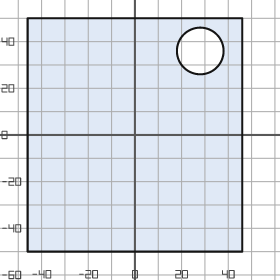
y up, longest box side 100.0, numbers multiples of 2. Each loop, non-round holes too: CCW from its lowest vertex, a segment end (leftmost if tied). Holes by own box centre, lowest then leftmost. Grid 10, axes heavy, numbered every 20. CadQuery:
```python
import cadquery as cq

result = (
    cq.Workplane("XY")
    .moveTo(-46.0, -50.0)
    .lineTo(46.0, -50.0)
    .lineTo(46.0, 50.0)
    .lineTo(-46.0, 50.0)
    .close()
    .moveTo(28.0, 36.0)
    .circle(10.0)
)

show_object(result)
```